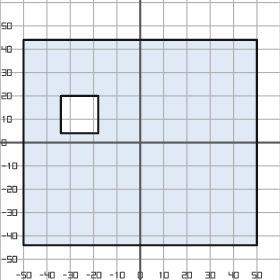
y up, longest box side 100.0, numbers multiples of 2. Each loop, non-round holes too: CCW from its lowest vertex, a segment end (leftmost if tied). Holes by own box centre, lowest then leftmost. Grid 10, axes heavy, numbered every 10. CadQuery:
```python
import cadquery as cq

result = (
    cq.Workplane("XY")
    .moveTo(-50.0, -44.0)
    .lineTo(50.0, -44.0)
    .lineTo(50.0, 44.0)
    .lineTo(-50.0, 44.0)
    .close()
    .moveTo(-34.0, 4.0)
    .lineTo(-18.0, 4.0)
    .lineTo(-18.0, 20.0)
    .lineTo(-34.0, 20.0)
    .close()
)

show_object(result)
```